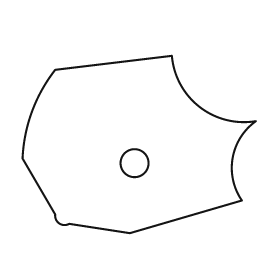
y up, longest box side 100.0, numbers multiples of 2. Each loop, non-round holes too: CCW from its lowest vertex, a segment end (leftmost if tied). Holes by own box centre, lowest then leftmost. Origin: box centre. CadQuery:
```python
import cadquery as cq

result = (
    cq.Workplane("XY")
    .moveTo(-4.0, -38.0)
    .lineTo(44.0, -24.0)
    .threePointArc((40.0, -6.0), (50.0, 10.0))
    .threePointArc((26.0, 16.0), (14.0, 38.0))
    .lineTo(-36.0, 32.0)
    .threePointArc((-46.0, 14.0), (-50.0, -6.0))
    .lineTo(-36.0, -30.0)
    .threePointArc((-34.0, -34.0), (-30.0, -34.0))
    .close()
    .moveTo(-2.0, -8.0)
    .circle(6.0)
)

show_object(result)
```